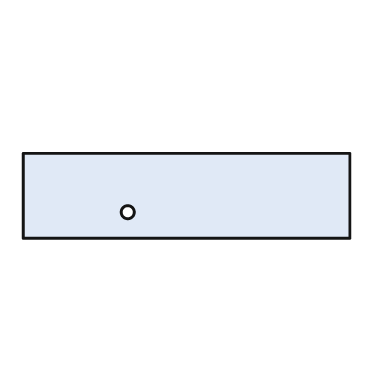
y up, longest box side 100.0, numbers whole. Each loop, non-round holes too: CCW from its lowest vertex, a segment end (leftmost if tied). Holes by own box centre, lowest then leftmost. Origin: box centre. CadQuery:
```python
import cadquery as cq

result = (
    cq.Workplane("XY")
    .moveTo(-50.0, -13.0)
    .lineTo(50.0, -13.0)
    .lineTo(50.0, 13.0)
    .lineTo(-50.0, 13.0)
    .close()
    .moveTo(-18.0, -5.0)
    .circle(2.0)
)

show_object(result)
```